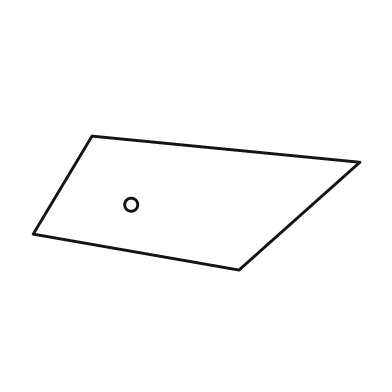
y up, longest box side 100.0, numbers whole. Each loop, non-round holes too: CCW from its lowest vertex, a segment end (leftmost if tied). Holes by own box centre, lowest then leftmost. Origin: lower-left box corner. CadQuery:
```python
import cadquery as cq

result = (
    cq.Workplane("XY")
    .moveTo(63.0, 0.0)
    .lineTo(100.0, 33.0)
    .lineTo(18.0, 41.0)
    .lineTo(0.0, 11.0)
    .close()
    .moveTo(30.0, 20.0)
    .circle(2.0)
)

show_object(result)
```